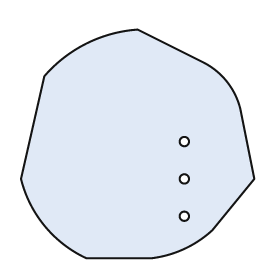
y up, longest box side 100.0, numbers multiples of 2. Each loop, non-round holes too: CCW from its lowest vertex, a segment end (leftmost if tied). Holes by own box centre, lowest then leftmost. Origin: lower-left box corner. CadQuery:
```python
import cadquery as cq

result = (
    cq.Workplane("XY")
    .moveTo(28.0, 0.0)
    .lineTo(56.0, 0.0)
    .threePointArc((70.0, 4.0), (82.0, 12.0))
    .lineTo(100.0, 34.0)
    .lineTo(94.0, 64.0)
    .threePointArc((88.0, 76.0), (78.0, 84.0))
    .lineTo(50.0, 98.0)
    .threePointArc((28.0, 92.0), (10.0, 78.0))
    .lineTo(0.0, 34.0)
    .threePointArc((10.0, 14.0), (28.0, 0.0))
    .close()
    .moveTo(70.0, 18.0)
    .circle(2.0)
    .moveTo(70.0, 34.0)
    .circle(2.0)
    .moveTo(70.0, 50.0)
    .circle(2.0)
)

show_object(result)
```